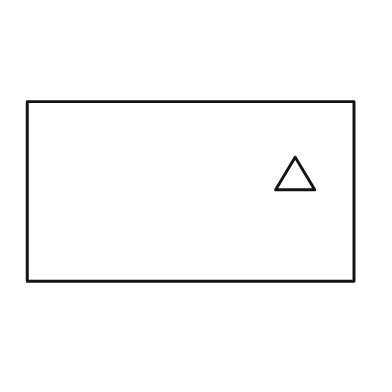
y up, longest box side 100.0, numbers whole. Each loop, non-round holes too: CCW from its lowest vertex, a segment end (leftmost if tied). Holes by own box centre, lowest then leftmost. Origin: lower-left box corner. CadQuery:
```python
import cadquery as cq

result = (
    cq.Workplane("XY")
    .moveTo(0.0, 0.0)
    .lineTo(100.0, 0.0)
    .lineTo(100.0, 55.0)
    .lineTo(0.0, 55.0)
    .close()
    .moveTo(76.0, 28.0)
    .lineTo(88.0, 28.0)
    .lineTo(82.0, 38.0)
    .close()
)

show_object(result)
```